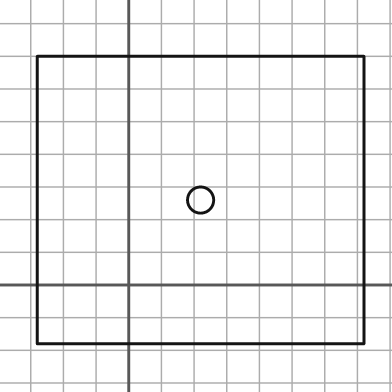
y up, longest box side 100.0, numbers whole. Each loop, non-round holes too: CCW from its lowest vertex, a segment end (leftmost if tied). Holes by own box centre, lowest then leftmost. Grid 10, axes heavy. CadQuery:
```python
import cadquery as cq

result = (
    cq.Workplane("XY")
    .moveTo(-28.0, -18.0)
    .lineTo(72.0, -18.0)
    .lineTo(72.0, 70.0)
    .lineTo(-28.0, 70.0)
    .close()
    .moveTo(22.0, 26.0)
    .circle(4.0)
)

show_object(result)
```